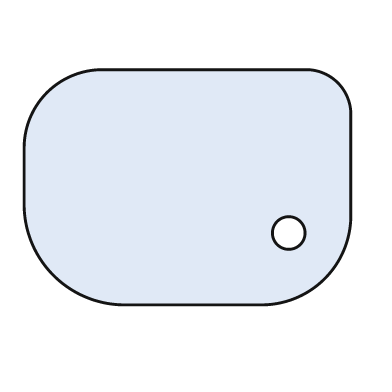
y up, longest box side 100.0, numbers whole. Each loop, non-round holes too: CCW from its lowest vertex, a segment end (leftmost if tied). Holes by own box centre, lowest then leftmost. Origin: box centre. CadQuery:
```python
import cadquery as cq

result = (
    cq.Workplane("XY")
    .moveTo(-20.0, -36.0)
    .lineTo(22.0, -36.0)
    .threePointArc((42.0, -28.0), (50.0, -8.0))
    .lineTo(50.0, 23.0)
    .threePointArc((46.0, 32.0), (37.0, 36.0))
    .lineTo(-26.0, 36.0)
    .threePointArc((-43.0, 29.0), (-50.0, 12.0))
    .lineTo(-50.0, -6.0)
    .threePointArc((-41.0, -27.0), (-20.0, -36.0))
    .close()
    .moveTo(31.0, -14.0)
    .circle(5.0)
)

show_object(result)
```